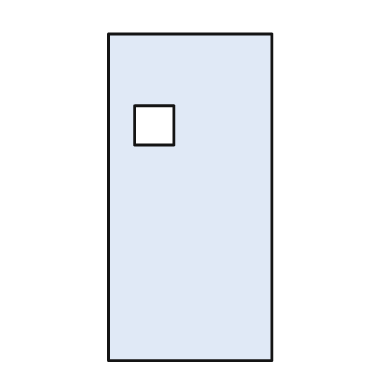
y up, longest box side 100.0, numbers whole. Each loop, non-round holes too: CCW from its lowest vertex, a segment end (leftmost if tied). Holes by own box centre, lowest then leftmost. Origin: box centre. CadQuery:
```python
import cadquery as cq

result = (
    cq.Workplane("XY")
    .moveTo(-25.0, -50.0)
    .lineTo(25.0, -50.0)
    .lineTo(25.0, 50.0)
    .lineTo(-25.0, 50.0)
    .close()
    .moveTo(-17.0, 16.0)
    .lineTo(-5.0, 16.0)
    .lineTo(-5.0, 28.0)
    .lineTo(-17.0, 28.0)
    .close()
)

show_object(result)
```